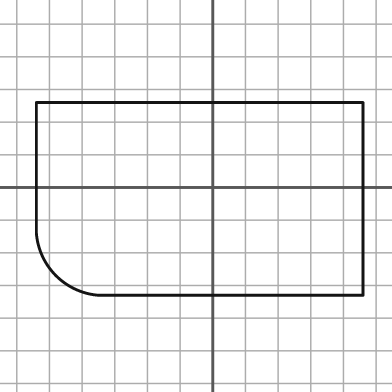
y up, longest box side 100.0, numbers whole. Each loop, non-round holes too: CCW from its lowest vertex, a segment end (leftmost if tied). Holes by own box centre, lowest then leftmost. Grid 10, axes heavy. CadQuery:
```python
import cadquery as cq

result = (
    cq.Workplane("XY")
    .moveTo(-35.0, -33.0)
    .lineTo(46.0, -33.0)
    .lineTo(46.0, 26.0)
    .lineTo(-54.0, 26.0)
    .lineTo(-54.0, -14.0)
    .threePointArc((-48.0, -27.0), (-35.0, -33.0))
    .close()
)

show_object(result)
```